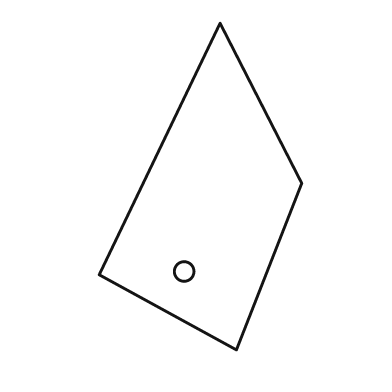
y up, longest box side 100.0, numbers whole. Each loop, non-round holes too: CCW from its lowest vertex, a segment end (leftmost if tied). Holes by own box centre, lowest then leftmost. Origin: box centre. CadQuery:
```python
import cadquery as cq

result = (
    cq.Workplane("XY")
    .moveTo(11.0, -50.0)
    .lineTo(31.0, 1.0)
    .lineTo(6.0, 50.0)
    .lineTo(-31.0, -27.0)
    .close()
    .moveTo(-5.0, -26.0)
    .circle(3.0)
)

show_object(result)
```